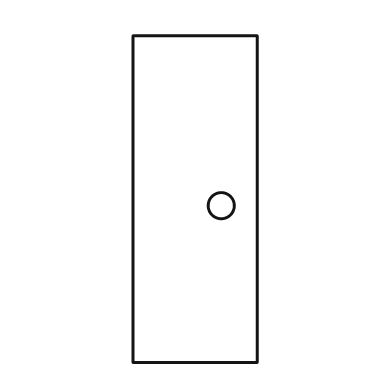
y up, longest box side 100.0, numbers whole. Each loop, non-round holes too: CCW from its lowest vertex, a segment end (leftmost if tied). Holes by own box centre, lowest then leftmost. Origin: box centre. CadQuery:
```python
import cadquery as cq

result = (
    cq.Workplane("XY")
    .moveTo(-19.0, -50.0)
    .lineTo(19.0, -50.0)
    .lineTo(19.0, 50.0)
    .lineTo(-19.0, 50.0)
    .close()
    .moveTo(8.0, -2.0)
    .circle(4.0)
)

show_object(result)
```